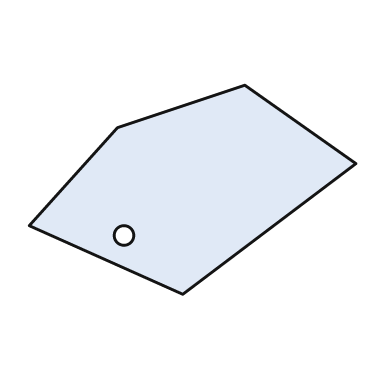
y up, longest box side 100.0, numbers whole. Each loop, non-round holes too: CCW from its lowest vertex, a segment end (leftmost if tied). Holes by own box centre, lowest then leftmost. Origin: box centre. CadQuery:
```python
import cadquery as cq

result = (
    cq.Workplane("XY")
    .moveTo(-3.0, -32.0)
    .lineTo(50.0, 8.0)
    .lineTo(16.0, 32.0)
    .lineTo(-23.0, 19.0)
    .lineTo(-50.0, -11.0)
    .close()
    .moveTo(-21.0, -14.0)
    .circle(3.0)
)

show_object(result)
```